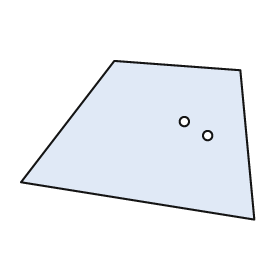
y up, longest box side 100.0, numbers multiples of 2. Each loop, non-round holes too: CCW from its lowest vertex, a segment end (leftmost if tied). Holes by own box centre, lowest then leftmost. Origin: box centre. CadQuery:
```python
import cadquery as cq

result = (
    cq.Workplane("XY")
    .moveTo(50.0, -34.0)
    .lineTo(44.0, 30.0)
    .lineTo(-10.0, 34.0)
    .lineTo(-50.0, -18.0)
    .close()
    .moveTo(30.0, 2.0)
    .circle(2.0)
    .moveTo(20.0, 8.0)
    .circle(2.0)
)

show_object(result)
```